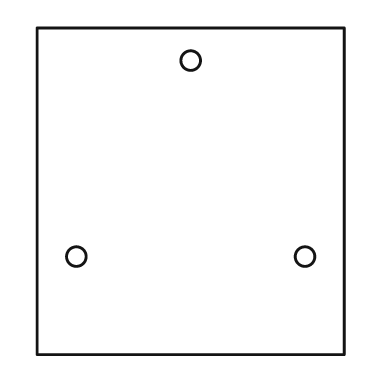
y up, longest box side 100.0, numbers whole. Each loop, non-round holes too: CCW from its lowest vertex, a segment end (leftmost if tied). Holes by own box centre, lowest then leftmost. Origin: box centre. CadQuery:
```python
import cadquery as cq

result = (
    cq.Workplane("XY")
    .moveTo(-47.0, -50.0)
    .lineTo(47.0, -50.0)
    .lineTo(47.0, 50.0)
    .lineTo(-47.0, 50.0)
    .close()
    .moveTo(-35.0, -20.0)
    .circle(3.0)
    .moveTo(35.0, -20.0)
    .circle(3.0)
    .moveTo(0.0, 40.0)
    .circle(3.0)
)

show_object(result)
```